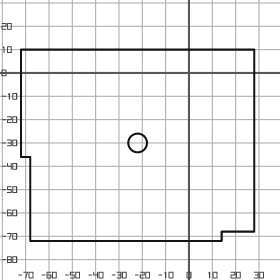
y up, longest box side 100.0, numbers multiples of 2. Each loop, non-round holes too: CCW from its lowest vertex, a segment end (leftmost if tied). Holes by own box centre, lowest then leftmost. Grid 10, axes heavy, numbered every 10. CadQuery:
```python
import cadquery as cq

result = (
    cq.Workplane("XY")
    .moveTo(-68.0, -72.0)
    .lineTo(14.0, -72.0)
    .lineTo(14.0, -68.0)
    .lineTo(28.0, -68.0)
    .lineTo(28.0, 10.0)
    .lineTo(-72.0, 10.0)
    .lineTo(-72.0, -36.0)
    .lineTo(-68.0, -36.0)
    .close()
    .moveTo(-22.0, -30.0)
    .circle(4.0)
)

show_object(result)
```